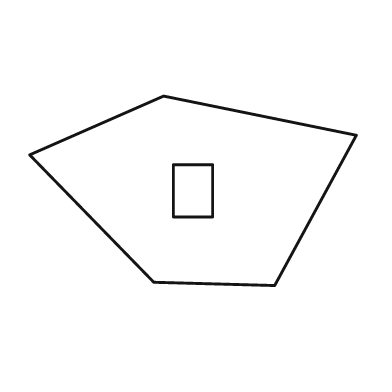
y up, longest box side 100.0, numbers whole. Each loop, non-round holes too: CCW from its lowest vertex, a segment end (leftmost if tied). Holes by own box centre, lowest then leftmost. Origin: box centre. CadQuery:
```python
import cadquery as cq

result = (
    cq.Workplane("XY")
    .moveTo(25.0, -29.0)
    .lineTo(50.0, 17.0)
    .lineTo(-9.0, 29.0)
    .lineTo(-50.0, 11.0)
    .lineTo(-12.0, -28.0)
    .close()
    .moveTo(-6.0, -8.0)
    .lineTo(6.0, -8.0)
    .lineTo(6.0, 8.0)
    .lineTo(-6.0, 8.0)
    .close()
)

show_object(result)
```